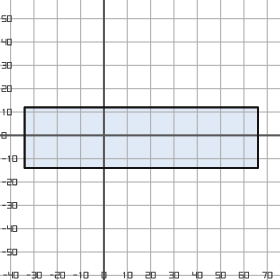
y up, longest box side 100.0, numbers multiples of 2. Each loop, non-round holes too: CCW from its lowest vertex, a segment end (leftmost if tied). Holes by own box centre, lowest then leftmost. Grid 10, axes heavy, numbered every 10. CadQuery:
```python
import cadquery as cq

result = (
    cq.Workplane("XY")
    .moveTo(-34.0, -14.0)
    .lineTo(66.0, -14.0)
    .lineTo(66.0, 12.0)
    .lineTo(-34.0, 12.0)
    .close()
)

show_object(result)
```